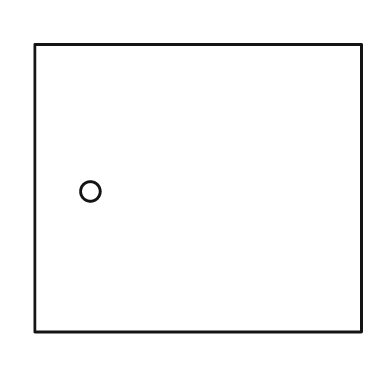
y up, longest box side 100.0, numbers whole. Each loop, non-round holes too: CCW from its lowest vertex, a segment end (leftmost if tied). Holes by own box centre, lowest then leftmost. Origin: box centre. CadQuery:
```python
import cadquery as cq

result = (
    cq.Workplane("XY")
    .moveTo(-50.0, -44.0)
    .lineTo(50.0, -44.0)
    .lineTo(50.0, 44.0)
    .lineTo(-50.0, 44.0)
    .close()
    .moveTo(-33.0, -1.0)
    .circle(3.0)
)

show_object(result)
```